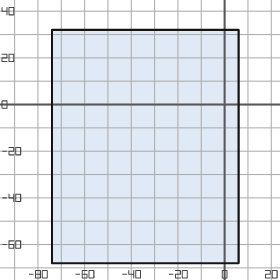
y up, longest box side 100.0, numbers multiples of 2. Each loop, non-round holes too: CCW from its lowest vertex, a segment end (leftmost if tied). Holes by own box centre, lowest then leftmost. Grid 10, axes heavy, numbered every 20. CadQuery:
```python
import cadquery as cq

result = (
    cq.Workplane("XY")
    .moveTo(-74.0, -68.0)
    .lineTo(6.0, -68.0)
    .lineTo(6.0, 32.0)
    .lineTo(-74.0, 32.0)
    .close()
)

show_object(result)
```